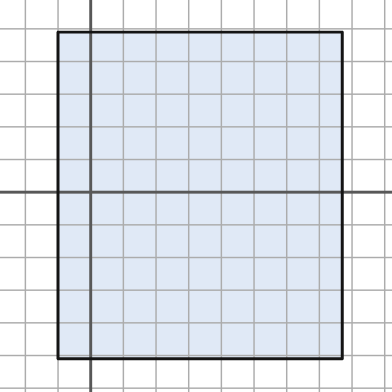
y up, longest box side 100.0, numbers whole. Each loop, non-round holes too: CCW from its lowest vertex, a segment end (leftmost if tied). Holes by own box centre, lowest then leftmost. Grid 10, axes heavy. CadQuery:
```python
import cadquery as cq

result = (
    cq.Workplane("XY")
    .moveTo(-10.0, -51.0)
    .lineTo(77.0, -51.0)
    .lineTo(77.0, 49.0)
    .lineTo(-10.0, 49.0)
    .close()
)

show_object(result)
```